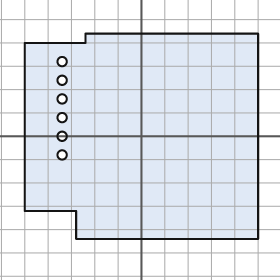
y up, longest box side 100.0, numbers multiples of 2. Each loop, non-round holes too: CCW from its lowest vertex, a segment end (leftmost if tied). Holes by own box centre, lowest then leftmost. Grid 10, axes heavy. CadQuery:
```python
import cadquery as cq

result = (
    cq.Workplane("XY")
    .moveTo(-28.0, -44.0)
    .lineTo(50.0, -44.0)
    .lineTo(50.0, 44.0)
    .lineTo(-24.0, 44.0)
    .lineTo(-24.0, 40.0)
    .lineTo(-50.0, 40.0)
    .lineTo(-50.0, -32.0)
    .lineTo(-28.0, -32.0)
    .close()
    .moveTo(-34.0, -8.0)
    .circle(2.0)
    .moveTo(-34.0, 0.0)
    .circle(2.0)
    .moveTo(-34.0, 8.0)
    .circle(2.0)
    .moveTo(-34.0, 16.0)
    .circle(2.0)
    .moveTo(-34.0, 24.0)
    .circle(2.0)
    .moveTo(-34.0, 32.0)
    .circle(2.0)
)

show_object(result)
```